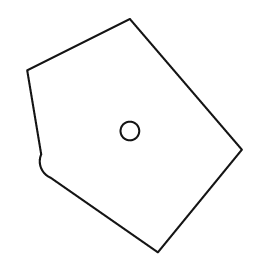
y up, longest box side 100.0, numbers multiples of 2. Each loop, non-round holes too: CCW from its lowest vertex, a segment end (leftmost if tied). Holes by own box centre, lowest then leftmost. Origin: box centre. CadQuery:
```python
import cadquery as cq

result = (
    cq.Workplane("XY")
    .moveTo(10.0, -50.0)
    .lineTo(46.0, -6.0)
    .lineTo(-2.0, 50.0)
    .lineTo(-46.0, 28.0)
    .lineTo(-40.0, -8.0)
    .threePointArc((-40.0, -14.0), (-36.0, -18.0))
    .close()
    .moveTo(-2.0, 2.0)
    .circle(4.0)
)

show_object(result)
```